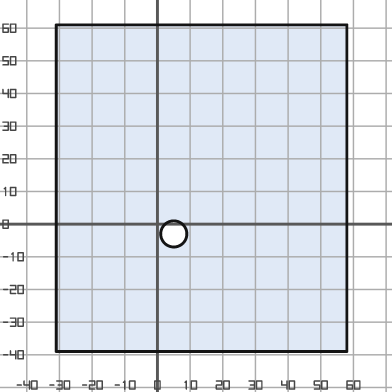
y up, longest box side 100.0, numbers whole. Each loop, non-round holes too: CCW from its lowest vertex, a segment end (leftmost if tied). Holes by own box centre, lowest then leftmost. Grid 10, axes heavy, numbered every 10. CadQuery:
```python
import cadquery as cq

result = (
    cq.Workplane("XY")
    .moveTo(-31.0, -39.0)
    .lineTo(58.0, -39.0)
    .lineTo(58.0, 61.0)
    .lineTo(-31.0, 61.0)
    .close()
    .moveTo(5.0, -3.0)
    .circle(4.0)
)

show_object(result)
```